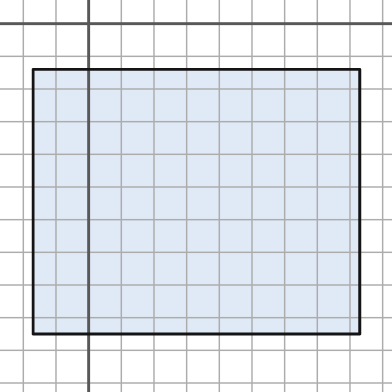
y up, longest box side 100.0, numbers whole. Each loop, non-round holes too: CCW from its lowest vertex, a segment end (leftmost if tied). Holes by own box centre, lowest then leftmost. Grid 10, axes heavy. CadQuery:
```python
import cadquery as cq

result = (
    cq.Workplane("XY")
    .moveTo(-17.0, -95.0)
    .lineTo(83.0, -95.0)
    .lineTo(83.0, -14.0)
    .lineTo(-17.0, -14.0)
    .close()
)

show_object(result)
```